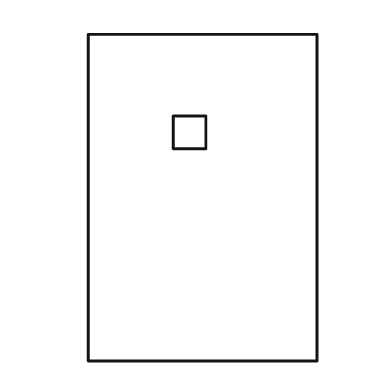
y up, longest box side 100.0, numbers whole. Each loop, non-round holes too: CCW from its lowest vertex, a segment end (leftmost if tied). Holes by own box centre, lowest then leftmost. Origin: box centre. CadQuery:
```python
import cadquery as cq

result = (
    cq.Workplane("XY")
    .moveTo(-35.0, -50.0)
    .lineTo(35.0, -50.0)
    .lineTo(35.0, 50.0)
    .lineTo(-35.0, 50.0)
    .close()
    .moveTo(-9.0, 15.0)
    .lineTo(1.0, 15.0)
    .lineTo(1.0, 25.0)
    .lineTo(-9.0, 25.0)
    .close()
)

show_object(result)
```